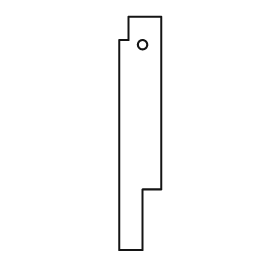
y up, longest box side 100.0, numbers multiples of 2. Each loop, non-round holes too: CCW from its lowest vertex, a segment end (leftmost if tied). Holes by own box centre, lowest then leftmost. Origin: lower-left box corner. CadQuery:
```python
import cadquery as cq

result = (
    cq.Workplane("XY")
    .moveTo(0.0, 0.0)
    .lineTo(10.0, 0.0)
    .lineTo(10.0, 26.0)
    .lineTo(18.0, 26.0)
    .lineTo(18.0, 100.0)
    .lineTo(4.0, 100.0)
    .lineTo(4.0, 90.0)
    .lineTo(0.0, 90.0)
    .close()
    .moveTo(10.0, 88.0)
    .circle(2.0)
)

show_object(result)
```